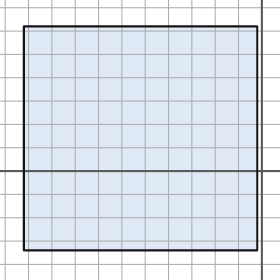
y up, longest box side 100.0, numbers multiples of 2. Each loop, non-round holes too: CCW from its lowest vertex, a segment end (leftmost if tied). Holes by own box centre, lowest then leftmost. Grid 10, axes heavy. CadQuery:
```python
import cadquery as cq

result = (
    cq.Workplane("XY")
    .moveTo(-102.0, -34.0)
    .lineTo(-2.0, -34.0)
    .lineTo(-2.0, 62.0)
    .lineTo(-102.0, 62.0)
    .close()
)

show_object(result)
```